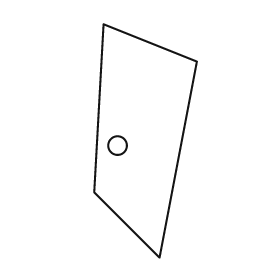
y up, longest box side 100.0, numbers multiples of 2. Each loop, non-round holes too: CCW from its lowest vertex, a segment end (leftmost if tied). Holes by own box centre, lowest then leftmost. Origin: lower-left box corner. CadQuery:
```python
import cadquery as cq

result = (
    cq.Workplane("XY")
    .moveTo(28.0, 0.0)
    .lineTo(44.0, 84.0)
    .lineTo(4.0, 100.0)
    .lineTo(0.0, 28.0)
    .close()
    .moveTo(10.0, 48.0)
    .circle(4.0)
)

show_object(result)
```